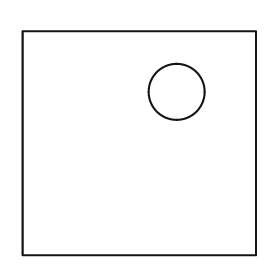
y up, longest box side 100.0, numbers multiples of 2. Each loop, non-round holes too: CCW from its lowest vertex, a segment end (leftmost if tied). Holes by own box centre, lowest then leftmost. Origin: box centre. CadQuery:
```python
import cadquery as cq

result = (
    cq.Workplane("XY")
    .moveTo(-50.0, -48.0)
    .lineTo(50.0, -48.0)
    .lineTo(50.0, 48.0)
    .lineTo(-50.0, 48.0)
    .close()
    .moveTo(16.0, 22.0)
    .circle(12.0)
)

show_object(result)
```